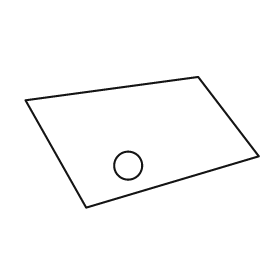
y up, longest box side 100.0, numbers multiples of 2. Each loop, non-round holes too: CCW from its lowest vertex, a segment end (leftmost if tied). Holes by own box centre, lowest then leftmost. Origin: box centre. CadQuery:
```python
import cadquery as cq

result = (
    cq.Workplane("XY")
    .moveTo(-24.0, -28.0)
    .lineTo(50.0, -6.0)
    .lineTo(24.0, 28.0)
    .lineTo(-50.0, 18.0)
    .close()
    .moveTo(-6.0, -10.0)
    .circle(6.0)
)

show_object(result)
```